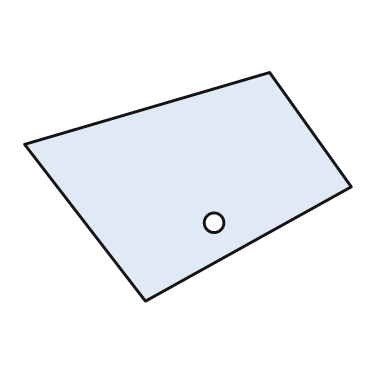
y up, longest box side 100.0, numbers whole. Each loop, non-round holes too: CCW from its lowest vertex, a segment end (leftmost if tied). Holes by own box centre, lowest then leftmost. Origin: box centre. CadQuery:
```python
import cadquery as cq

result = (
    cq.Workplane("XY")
    .moveTo(-13.0, -35.0)
    .lineTo(50.0, 0.0)
    .lineTo(25.0, 35.0)
    .lineTo(-50.0, 13.0)
    .close()
    .moveTo(8.0, -11.0)
    .circle(3.0)
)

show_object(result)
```